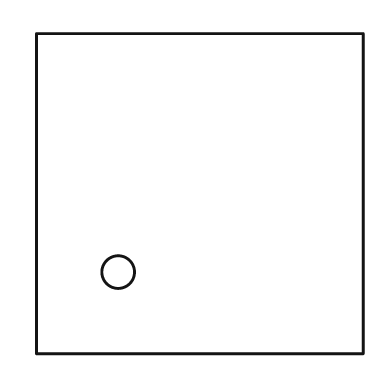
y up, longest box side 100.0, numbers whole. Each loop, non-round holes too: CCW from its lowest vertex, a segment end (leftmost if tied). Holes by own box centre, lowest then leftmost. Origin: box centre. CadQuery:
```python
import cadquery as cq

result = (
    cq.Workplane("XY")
    .moveTo(-50.0, -49.0)
    .lineTo(50.0, -49.0)
    .lineTo(50.0, 49.0)
    .lineTo(-50.0, 49.0)
    .close()
    .moveTo(-25.0, -24.0)
    .circle(5.0)
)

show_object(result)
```